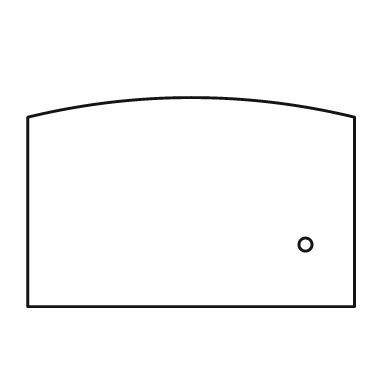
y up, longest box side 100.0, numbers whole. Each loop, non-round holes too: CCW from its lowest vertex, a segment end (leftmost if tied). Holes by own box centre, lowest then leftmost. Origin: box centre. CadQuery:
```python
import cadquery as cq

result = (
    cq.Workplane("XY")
    .moveTo(-50.0, -32.0)
    .lineTo(50.0, -32.0)
    .lineTo(50.0, 26.0)
    .threePointArc((0.0, 32.0), (-50.0, 26.0))
    .close()
    .moveTo(35.0, -13.0)
    .circle(2.0)
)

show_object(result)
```